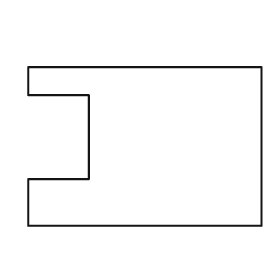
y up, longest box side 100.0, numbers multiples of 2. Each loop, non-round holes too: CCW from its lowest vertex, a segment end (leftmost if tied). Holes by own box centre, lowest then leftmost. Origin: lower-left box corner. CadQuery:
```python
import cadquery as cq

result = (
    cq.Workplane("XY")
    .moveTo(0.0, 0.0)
    .lineTo(100.0, 0.0)
    .lineTo(100.0, 68.0)
    .lineTo(0.0, 68.0)
    .lineTo(0.0, 56.0)
    .lineTo(26.0, 56.0)
    .lineTo(26.0, 20.0)
    .lineTo(0.0, 20.0)
    .close()
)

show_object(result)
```